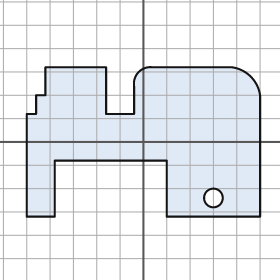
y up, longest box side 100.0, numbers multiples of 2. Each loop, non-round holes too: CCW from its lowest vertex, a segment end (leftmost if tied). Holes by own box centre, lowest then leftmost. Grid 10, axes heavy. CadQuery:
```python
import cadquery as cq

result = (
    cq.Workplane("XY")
    .moveTo(-50.0, -32.0)
    .lineTo(-38.0, -32.0)
    .lineTo(-38.0, -8.0)
    .lineTo(10.0, -8.0)
    .lineTo(10.0, -32.0)
    .lineTo(50.0, -32.0)
    .lineTo(50.0, 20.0)
    .threePointArc((46.0, 28.0), (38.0, 32.0))
    .lineTo(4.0, 32.0)
    .threePointArc((-2.0, 30.0), (-4.0, 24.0))
    .lineTo(-4.0, 12.0)
    .lineTo(-16.0, 12.0)
    .lineTo(-16.0, 32.0)
    .lineTo(-42.0, 32.0)
    .lineTo(-42.0, 20.0)
    .lineTo(-46.0, 20.0)
    .lineTo(-46.0, 12.0)
    .lineTo(-50.0, 12.0)
    .close()
    .moveTo(30.0, -24.0)
    .circle(4.0)
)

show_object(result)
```